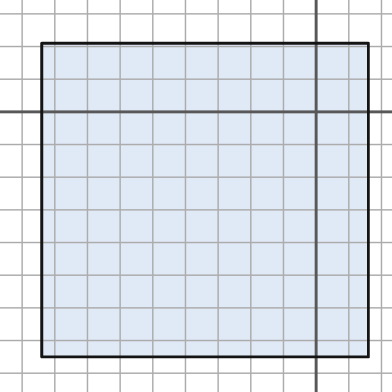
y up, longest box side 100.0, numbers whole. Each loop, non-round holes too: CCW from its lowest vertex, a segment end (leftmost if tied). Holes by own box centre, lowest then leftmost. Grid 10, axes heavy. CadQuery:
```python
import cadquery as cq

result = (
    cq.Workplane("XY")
    .moveTo(-84.0, -75.0)
    .lineTo(16.0, -75.0)
    .lineTo(16.0, 21.0)
    .lineTo(-84.0, 21.0)
    .close()
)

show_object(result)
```